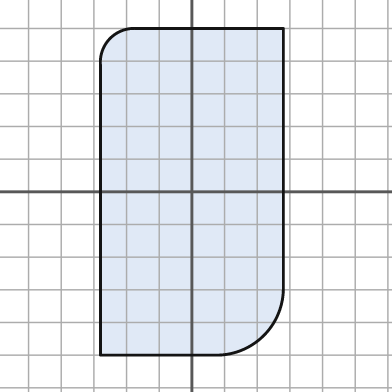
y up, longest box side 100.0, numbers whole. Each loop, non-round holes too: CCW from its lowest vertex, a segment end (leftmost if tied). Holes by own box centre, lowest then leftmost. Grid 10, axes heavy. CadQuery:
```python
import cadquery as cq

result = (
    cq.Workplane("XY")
    .moveTo(-28.0, -50.0)
    .lineTo(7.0, -50.0)
    .threePointArc((22.0, -44.0), (28.0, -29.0))
    .lineTo(28.0, 50.0)
    .lineTo(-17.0, 50.0)
    .threePointArc((-25.0, 47.0), (-28.0, 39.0))
    .close()
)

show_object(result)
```